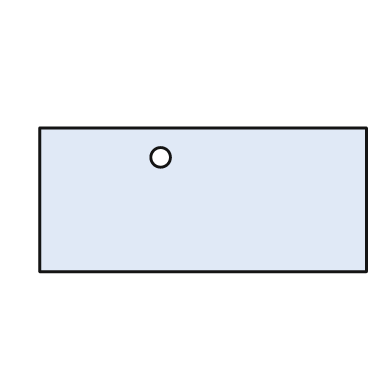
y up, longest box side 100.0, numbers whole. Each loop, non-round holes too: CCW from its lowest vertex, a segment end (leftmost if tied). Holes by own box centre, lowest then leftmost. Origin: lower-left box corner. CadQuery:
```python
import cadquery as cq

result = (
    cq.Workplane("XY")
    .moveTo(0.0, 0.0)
    .lineTo(100.0, 0.0)
    .lineTo(100.0, 44.0)
    .lineTo(0.0, 44.0)
    .close()
    .moveTo(37.0, 35.0)
    .circle(3.0)
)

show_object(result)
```